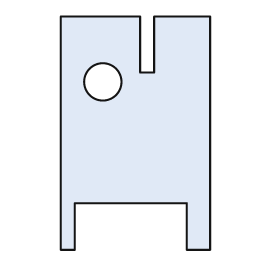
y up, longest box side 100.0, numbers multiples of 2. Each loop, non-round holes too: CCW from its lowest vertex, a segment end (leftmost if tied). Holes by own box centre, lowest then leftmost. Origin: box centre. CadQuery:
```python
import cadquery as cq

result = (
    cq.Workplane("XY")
    .moveTo(-32.0, -50.0)
    .lineTo(-26.0, -50.0)
    .lineTo(-26.0, -30.0)
    .lineTo(22.0, -30.0)
    .lineTo(22.0, -50.0)
    .lineTo(32.0, -50.0)
    .lineTo(32.0, 50.0)
    .lineTo(8.0, 50.0)
    .lineTo(8.0, 26.0)
    .lineTo(2.0, 26.0)
    .lineTo(2.0, 50.0)
    .lineTo(-32.0, 50.0)
    .close()
    .moveTo(-14.0, 22.0)
    .circle(8.0)
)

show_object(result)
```